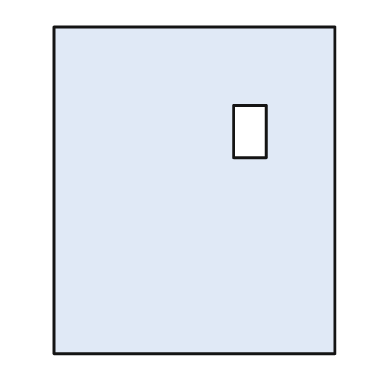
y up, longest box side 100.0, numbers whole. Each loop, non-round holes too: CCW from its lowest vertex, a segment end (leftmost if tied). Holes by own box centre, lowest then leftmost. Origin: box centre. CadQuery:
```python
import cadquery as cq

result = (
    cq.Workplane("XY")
    .moveTo(-43.0, -50.0)
    .lineTo(43.0, -50.0)
    .lineTo(43.0, 50.0)
    .lineTo(-43.0, 50.0)
    .close()
    .moveTo(12.0, 10.0)
    .lineTo(22.0, 10.0)
    .lineTo(22.0, 26.0)
    .lineTo(12.0, 26.0)
    .close()
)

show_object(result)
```